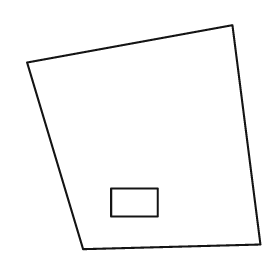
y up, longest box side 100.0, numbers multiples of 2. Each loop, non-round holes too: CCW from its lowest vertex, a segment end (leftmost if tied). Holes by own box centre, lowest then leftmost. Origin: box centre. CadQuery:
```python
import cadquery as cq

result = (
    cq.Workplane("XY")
    .moveTo(-26.0, -48.0)
    .lineTo(50.0, -46.0)
    .lineTo(38.0, 48.0)
    .lineTo(-50.0, 32.0)
    .close()
    .moveTo(-14.0, -34.0)
    .lineTo(6.0, -34.0)
    .lineTo(6.0, -22.0)
    .lineTo(-14.0, -22.0)
    .close()
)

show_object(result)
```